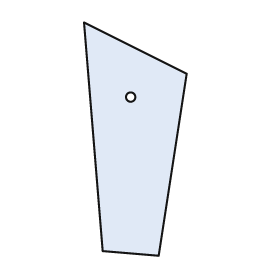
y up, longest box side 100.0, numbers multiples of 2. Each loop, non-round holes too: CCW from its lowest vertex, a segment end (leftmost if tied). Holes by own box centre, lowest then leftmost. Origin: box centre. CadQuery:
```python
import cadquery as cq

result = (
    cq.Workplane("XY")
    .moveTo(10.0, -50.0)
    .lineTo(22.0, 28.0)
    .lineTo(-22.0, 50.0)
    .lineTo(-14.0, -48.0)
    .close()
    .moveTo(-2.0, 18.0)
    .circle(2.0)
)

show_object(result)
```